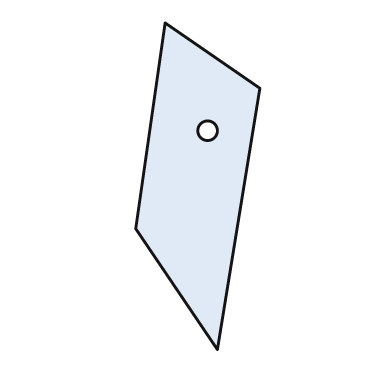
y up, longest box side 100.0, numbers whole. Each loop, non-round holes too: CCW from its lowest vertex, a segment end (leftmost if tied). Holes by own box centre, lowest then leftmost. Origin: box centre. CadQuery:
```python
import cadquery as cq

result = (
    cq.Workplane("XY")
    .moveTo(6.0, -50.0)
    .lineTo(19.0, 30.0)
    .lineTo(-10.0, 50.0)
    .lineTo(-19.0, -13.0)
    .close()
    .moveTo(3.0, 17.0)
    .circle(3.0)
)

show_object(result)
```